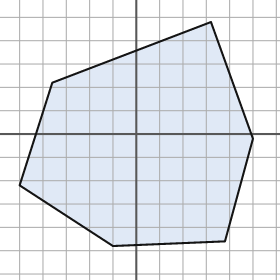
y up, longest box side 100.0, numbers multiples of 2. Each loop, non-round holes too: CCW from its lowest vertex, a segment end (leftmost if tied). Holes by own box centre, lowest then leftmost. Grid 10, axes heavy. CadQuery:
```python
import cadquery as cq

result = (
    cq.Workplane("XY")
    .moveTo(-10.0, -48.0)
    .lineTo(38.0, -46.0)
    .lineTo(50.0, -2.0)
    .lineTo(32.0, 48.0)
    .lineTo(-36.0, 22.0)
    .lineTo(-50.0, -22.0)
    .close()
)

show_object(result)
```